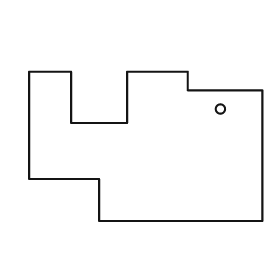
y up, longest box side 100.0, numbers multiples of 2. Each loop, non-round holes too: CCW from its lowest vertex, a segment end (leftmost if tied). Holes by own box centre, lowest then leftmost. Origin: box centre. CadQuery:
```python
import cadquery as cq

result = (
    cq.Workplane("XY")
    .moveTo(-20.0, -32.0)
    .lineTo(50.0, -32.0)
    .lineTo(50.0, 24.0)
    .lineTo(18.0, 24.0)
    .lineTo(18.0, 32.0)
    .lineTo(-8.0, 32.0)
    .lineTo(-8.0, 10.0)
    .lineTo(-32.0, 10.0)
    .lineTo(-32.0, 32.0)
    .lineTo(-50.0, 32.0)
    .lineTo(-50.0, -14.0)
    .lineTo(-20.0, -14.0)
    .close()
    .moveTo(32.0, 16.0)
    .circle(2.0)
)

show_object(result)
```